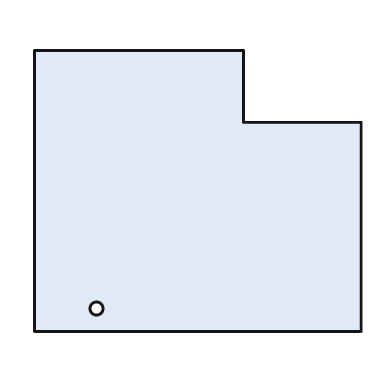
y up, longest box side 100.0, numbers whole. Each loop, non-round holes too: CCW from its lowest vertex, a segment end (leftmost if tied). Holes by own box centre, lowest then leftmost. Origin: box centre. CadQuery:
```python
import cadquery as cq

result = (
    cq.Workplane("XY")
    .moveTo(-50.0, -43.0)
    .lineTo(50.0, -43.0)
    .lineTo(50.0, 21.0)
    .lineTo(14.0, 21.0)
    .lineTo(14.0, 43.0)
    .lineTo(-50.0, 43.0)
    .close()
    .moveTo(-31.0, -36.0)
    .circle(2.0)
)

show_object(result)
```